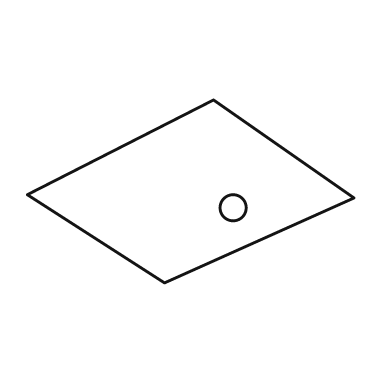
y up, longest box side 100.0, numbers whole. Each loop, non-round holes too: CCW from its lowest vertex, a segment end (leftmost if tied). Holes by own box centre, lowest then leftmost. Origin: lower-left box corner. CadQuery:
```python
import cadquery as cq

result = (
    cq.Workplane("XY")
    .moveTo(42.0, 0.0)
    .lineTo(100.0, 26.0)
    .lineTo(57.0, 56.0)
    .lineTo(0.0, 27.0)
    .close()
    .moveTo(63.0, 23.0)
    .circle(4.0)
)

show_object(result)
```